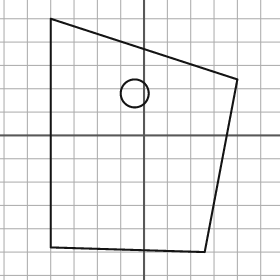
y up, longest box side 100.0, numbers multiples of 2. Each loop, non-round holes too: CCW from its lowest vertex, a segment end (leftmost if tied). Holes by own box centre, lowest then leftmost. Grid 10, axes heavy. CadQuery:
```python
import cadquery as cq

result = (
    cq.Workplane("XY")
    .moveTo(26.0, -50.0)
    .lineTo(40.0, 24.0)
    .lineTo(-40.0, 50.0)
    .lineTo(-40.0, -48.0)
    .close()
    .moveTo(-4.0, 18.0)
    .circle(6.0)
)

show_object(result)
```